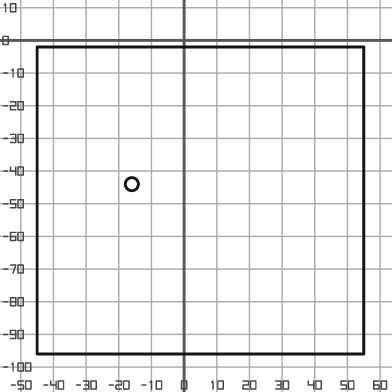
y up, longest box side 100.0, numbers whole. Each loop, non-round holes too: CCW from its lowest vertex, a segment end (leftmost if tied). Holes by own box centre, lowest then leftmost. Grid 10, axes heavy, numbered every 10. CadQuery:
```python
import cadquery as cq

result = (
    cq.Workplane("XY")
    .moveTo(-45.0, -96.0)
    .lineTo(55.0, -96.0)
    .lineTo(55.0, -2.0)
    .lineTo(-45.0, -2.0)
    .close()
    .moveTo(-16.0, -44.0)
    .circle(2.0)
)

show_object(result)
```